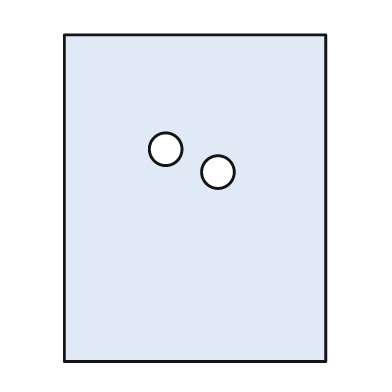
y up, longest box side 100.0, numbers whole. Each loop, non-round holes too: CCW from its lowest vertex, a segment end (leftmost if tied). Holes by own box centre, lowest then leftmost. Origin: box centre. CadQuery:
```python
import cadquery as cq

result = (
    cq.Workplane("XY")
    .moveTo(-40.0, -50.0)
    .lineTo(40.0, -50.0)
    .lineTo(40.0, 50.0)
    .lineTo(-40.0, 50.0)
    .close()
    .moveTo(7.0, 8.0)
    .circle(5.0)
    .moveTo(-9.0, 15.0)
    .circle(5.0)
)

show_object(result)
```